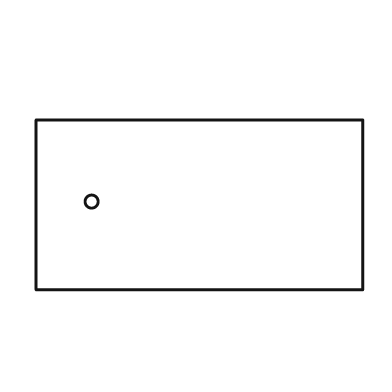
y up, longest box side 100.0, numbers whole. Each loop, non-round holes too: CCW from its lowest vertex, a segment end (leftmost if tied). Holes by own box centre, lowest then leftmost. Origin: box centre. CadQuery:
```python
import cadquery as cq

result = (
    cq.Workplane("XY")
    .moveTo(-50.0, -26.0)
    .lineTo(50.0, -26.0)
    .lineTo(50.0, 26.0)
    .lineTo(-50.0, 26.0)
    .close()
    .moveTo(-33.0, 1.0)
    .circle(2.0)
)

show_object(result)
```